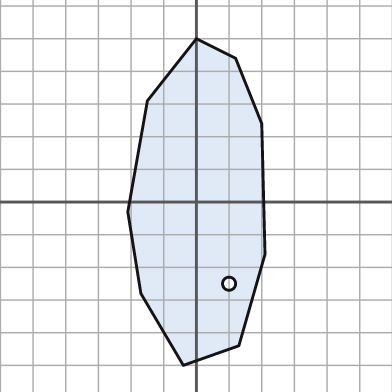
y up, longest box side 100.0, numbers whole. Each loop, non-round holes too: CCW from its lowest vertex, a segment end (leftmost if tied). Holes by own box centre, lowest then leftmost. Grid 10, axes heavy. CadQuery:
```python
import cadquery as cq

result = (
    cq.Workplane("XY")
    .moveTo(-4.0, -50.0)
    .lineTo(13.0, -44.0)
    .lineTo(21.0, -16.0)
    .lineTo(20.0, 24.0)
    .lineTo(12.0, 44.0)
    .lineTo(0.0, 50.0)
    .lineTo(-15.0, 31.0)
    .lineTo(-21.0, -3.0)
    .lineTo(-17.0, -28.0)
    .close()
    .moveTo(10.0, -25.0)
    .circle(2.0)
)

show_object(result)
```